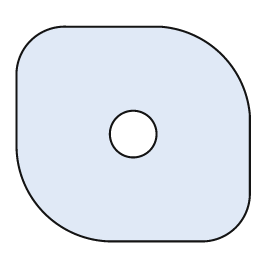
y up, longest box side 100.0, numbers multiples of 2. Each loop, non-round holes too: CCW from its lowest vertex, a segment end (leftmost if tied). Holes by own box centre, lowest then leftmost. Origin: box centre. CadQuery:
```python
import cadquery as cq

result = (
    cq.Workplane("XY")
    .moveTo(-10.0, -46.0)
    .lineTo(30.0, -46.0)
    .threePointArc((44.0, -40.0), (50.0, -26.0))
    .lineTo(50.0, 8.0)
    .threePointArc((38.0, 34.0), (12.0, 46.0))
    .lineTo(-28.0, 46.0)
    .threePointArc((-44.0, 40.0), (-50.0, 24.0))
    .lineTo(-50.0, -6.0)
    .threePointArc((-38.0, -34.0), (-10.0, -46.0))
    .close()
    .moveTo(0.0, 0.0)
    .circle(10.0)
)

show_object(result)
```